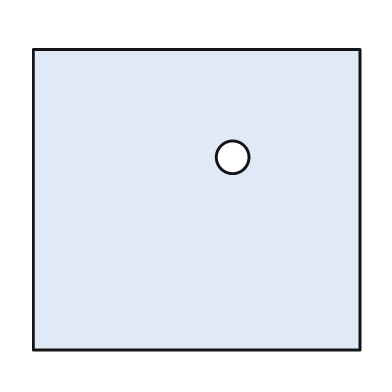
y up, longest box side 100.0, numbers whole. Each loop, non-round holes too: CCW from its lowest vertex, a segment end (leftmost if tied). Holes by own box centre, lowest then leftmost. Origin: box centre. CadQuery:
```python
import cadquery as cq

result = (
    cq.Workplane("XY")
    .moveTo(-50.0, -46.0)
    .lineTo(50.0, -46.0)
    .lineTo(50.0, 46.0)
    .lineTo(-50.0, 46.0)
    .close()
    .moveTo(11.0, 13.0)
    .circle(5.0)
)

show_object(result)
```